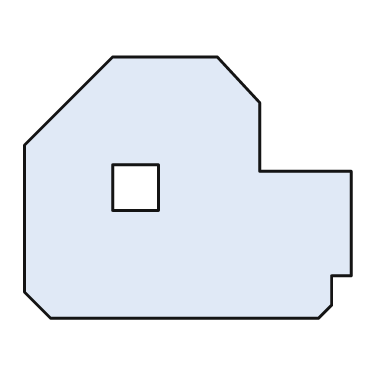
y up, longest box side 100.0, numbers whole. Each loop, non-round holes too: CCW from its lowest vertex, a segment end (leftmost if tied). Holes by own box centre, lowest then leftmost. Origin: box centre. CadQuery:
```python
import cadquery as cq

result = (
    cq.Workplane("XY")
    .moveTo(-42.0, -40.0)
    .lineTo(40.0, -40.0)
    .lineTo(44.0, -36.0)
    .lineTo(44.0, -27.0)
    .lineTo(50.0, -27.0)
    .lineTo(50.0, 5.0)
    .lineTo(22.0, 5.0)
    .lineTo(22.0, 26.0)
    .lineTo(9.0, 40.0)
    .lineTo(-23.0, 40.0)
    .lineTo(-50.0, 13.0)
    .lineTo(-50.0, -32.0)
    .close()
    .moveTo(-23.0, -7.0)
    .lineTo(-9.0, -7.0)
    .lineTo(-9.0, 7.0)
    .lineTo(-23.0, 7.0)
    .close()
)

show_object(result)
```